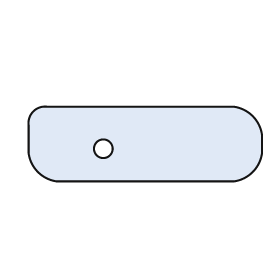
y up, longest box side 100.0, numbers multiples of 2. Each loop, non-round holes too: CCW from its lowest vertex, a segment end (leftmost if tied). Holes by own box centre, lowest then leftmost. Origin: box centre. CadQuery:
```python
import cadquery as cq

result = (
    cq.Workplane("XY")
    .moveTo(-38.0, -16.0)
    .lineTo(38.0, -16.0)
    .threePointArc((46.0, -12.0), (50.0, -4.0))
    .lineTo(50.0, 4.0)
    .threePointArc((46.0, 12.0), (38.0, 16.0))
    .lineTo(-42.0, 16.0)
    .threePointArc((-48.0, 14.0), (-50.0, 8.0))
    .lineTo(-50.0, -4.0)
    .threePointArc((-46.0, -12.0), (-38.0, -16.0))
    .close()
    .moveTo(-18.0, -2.0)
    .circle(4.0)
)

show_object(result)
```